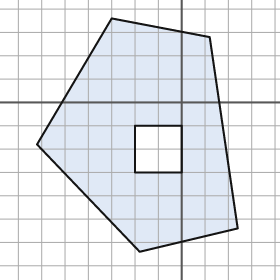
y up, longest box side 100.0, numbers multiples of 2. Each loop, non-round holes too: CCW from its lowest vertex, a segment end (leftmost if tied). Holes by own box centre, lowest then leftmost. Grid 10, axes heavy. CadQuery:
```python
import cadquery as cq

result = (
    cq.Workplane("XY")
    .moveTo(-18.0, -64.0)
    .lineTo(24.0, -54.0)
    .lineTo(12.0, 28.0)
    .lineTo(-30.0, 36.0)
    .lineTo(-62.0, -18.0)
    .close()
    .moveTo(-20.0, -30.0)
    .lineTo(0.0, -30.0)
    .lineTo(0.0, -10.0)
    .lineTo(-20.0, -10.0)
    .close()
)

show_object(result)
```